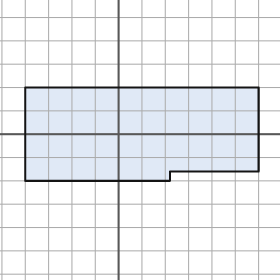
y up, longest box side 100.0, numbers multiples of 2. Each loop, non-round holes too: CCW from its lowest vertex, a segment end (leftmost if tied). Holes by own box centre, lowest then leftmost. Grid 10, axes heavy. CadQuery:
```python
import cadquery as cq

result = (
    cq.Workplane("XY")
    .moveTo(-40.0, -20.0)
    .lineTo(22.0, -20.0)
    .lineTo(22.0, -16.0)
    .lineTo(60.0, -16.0)
    .lineTo(60.0, 20.0)
    .lineTo(-40.0, 20.0)
    .close()
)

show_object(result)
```